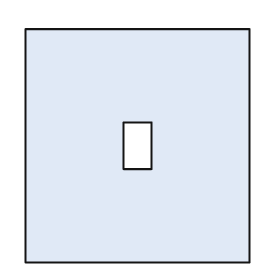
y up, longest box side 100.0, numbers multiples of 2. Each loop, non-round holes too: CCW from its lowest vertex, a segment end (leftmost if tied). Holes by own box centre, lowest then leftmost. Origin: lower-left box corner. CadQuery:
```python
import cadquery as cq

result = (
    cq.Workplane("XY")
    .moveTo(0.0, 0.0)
    .lineTo(96.0, 0.0)
    .lineTo(96.0, 100.0)
    .lineTo(0.0, 100.0)
    .close()
    .moveTo(42.0, 40.0)
    .lineTo(54.0, 40.0)
    .lineTo(54.0, 60.0)
    .lineTo(42.0, 60.0)
    .close()
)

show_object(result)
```